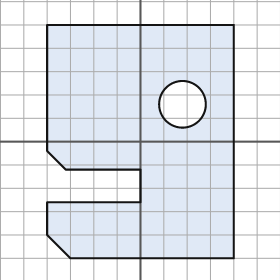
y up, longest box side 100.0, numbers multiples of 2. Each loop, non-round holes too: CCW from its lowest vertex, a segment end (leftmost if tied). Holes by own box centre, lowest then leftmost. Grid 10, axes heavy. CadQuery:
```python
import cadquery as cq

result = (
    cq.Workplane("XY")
    .moveTo(-30.0, -50.0)
    .lineTo(40.0, -50.0)
    .lineTo(40.0, 50.0)
    .lineTo(-40.0, 50.0)
    .lineTo(-40.0, -4.0)
    .lineTo(-32.0, -12.0)
    .lineTo(0.0, -12.0)
    .lineTo(0.0, -26.0)
    .lineTo(-40.0, -26.0)
    .lineTo(-40.0, -40.0)
    .close()
    .moveTo(18.0, 16.0)
    .circle(10.0)
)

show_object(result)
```